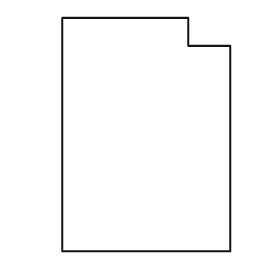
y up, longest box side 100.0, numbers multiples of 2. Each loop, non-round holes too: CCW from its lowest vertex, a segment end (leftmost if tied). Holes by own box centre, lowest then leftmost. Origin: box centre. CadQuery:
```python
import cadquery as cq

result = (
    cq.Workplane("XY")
    .moveTo(-36.0, -50.0)
    .lineTo(36.0, -50.0)
    .lineTo(36.0, 38.0)
    .lineTo(18.0, 38.0)
    .lineTo(18.0, 50.0)
    .lineTo(-36.0, 50.0)
    .close()
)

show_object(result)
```